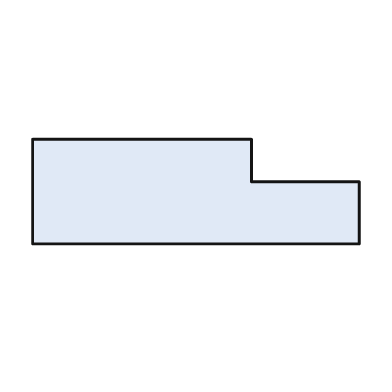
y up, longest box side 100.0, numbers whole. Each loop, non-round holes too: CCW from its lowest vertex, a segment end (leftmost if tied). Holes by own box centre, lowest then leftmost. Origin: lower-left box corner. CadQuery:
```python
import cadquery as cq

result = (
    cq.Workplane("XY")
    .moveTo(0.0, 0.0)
    .lineTo(100.0, 0.0)
    .lineTo(100.0, 19.0)
    .lineTo(67.0, 19.0)
    .lineTo(67.0, 32.0)
    .lineTo(0.0, 32.0)
    .close()
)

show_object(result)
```